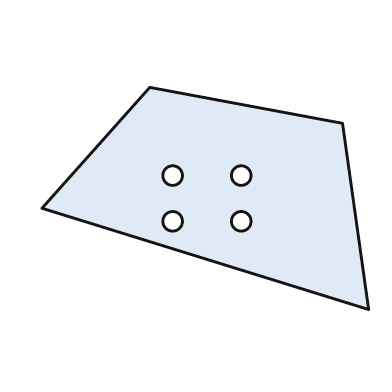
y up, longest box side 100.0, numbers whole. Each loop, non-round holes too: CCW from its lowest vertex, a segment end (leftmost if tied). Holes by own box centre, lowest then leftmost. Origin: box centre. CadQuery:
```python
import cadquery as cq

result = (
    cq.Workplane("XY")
    .moveTo(50.0, -34.0)
    .lineTo(42.0, 23.0)
    .lineTo(-17.0, 34.0)
    .lineTo(-50.0, -3.0)
    .close()
    .moveTo(-10.0, -7.0)
    .circle(3.0)
    .moveTo(11.0, -7.0)
    .circle(3.0)
    .moveTo(-10.0, 7.0)
    .circle(3.0)
    .moveTo(11.0, 7.0)
    .circle(3.0)
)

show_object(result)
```